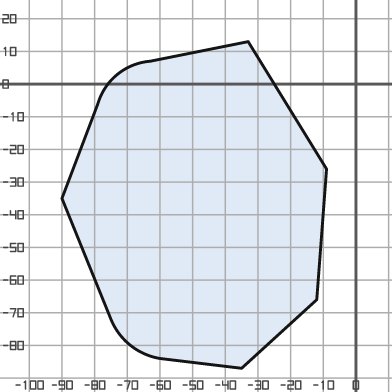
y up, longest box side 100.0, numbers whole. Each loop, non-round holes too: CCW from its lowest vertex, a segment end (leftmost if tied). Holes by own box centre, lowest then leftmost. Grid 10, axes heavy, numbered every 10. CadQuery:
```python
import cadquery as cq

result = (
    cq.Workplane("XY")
    .moveTo(-35.0, -87.0)
    .lineTo(-12.0, -66.0)
    .lineTo(-9.0, -26.0)
    .lineTo(-33.0, 13.0)
    .lineTo(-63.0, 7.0)
    .threePointArc((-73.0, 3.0), (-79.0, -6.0))
    .lineTo(-90.0, -35.0)
    .lineTo(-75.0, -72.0)
    .threePointArc((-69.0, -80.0), (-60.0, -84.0))
    .close()
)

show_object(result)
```